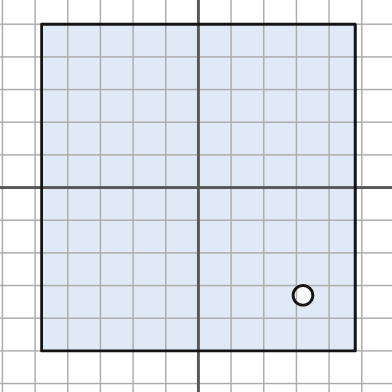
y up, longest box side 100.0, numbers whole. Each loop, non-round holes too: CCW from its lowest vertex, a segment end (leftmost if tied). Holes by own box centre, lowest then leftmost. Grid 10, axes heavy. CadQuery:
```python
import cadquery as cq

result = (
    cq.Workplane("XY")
    .moveTo(-48.0, -50.0)
    .lineTo(48.0, -50.0)
    .lineTo(48.0, 50.0)
    .lineTo(-48.0, 50.0)
    .close()
    .moveTo(32.0, -33.0)
    .circle(3.0)
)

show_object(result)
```